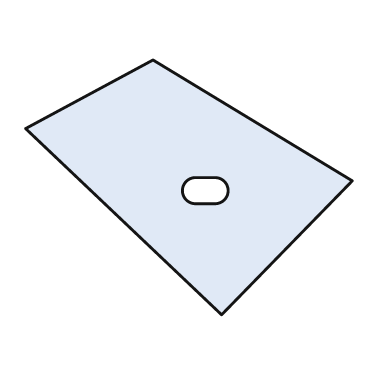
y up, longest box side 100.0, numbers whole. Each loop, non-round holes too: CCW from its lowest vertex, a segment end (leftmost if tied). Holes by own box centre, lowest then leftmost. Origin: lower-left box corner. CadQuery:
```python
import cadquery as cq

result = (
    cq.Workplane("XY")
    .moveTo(60.0, 0.0)
    .lineTo(100.0, 41.0)
    .lineTo(39.0, 78.0)
    .lineTo(0.0, 57.0)
    .close()
    .moveTo(52.0, 34.0)
    .lineTo(58.0, 34.0)
    .threePointArc((62.0, 38.0), (58.0, 42.0))
    .lineTo(52.0, 42.0)
    .threePointArc((48.0, 38.0), (52.0, 34.0))
    .close()
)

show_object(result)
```